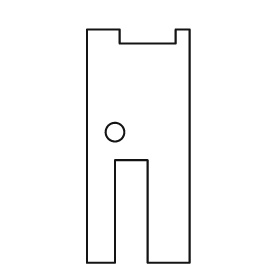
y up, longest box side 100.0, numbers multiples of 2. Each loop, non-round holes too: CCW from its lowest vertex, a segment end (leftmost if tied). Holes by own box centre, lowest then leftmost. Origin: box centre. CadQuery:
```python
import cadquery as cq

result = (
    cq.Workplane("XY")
    .moveTo(-22.0, -50.0)
    .lineTo(-10.0, -50.0)
    .lineTo(-10.0, -6.0)
    .lineTo(4.0, -6.0)
    .lineTo(4.0, -50.0)
    .lineTo(22.0, -50.0)
    .lineTo(22.0, 50.0)
    .lineTo(16.0, 50.0)
    .lineTo(16.0, 44.0)
    .lineTo(-8.0, 44.0)
    .lineTo(-8.0, 50.0)
    .lineTo(-22.0, 50.0)
    .close()
    .moveTo(-10.0, 6.0)
    .circle(4.0)
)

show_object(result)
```